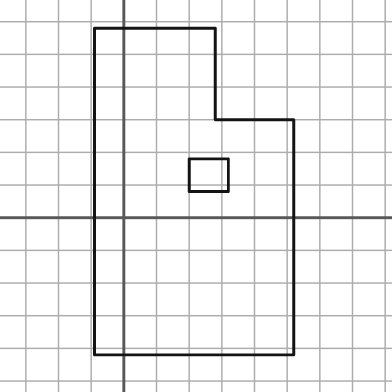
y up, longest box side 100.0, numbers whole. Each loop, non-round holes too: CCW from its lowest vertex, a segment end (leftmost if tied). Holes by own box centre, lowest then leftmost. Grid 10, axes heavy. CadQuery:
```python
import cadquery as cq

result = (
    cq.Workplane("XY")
    .moveTo(-9.0, -42.0)
    .lineTo(52.0, -42.0)
    .lineTo(52.0, 30.0)
    .lineTo(28.0, 30.0)
    .lineTo(28.0, 58.0)
    .lineTo(-9.0, 58.0)
    .close()
    .moveTo(20.0, 8.0)
    .lineTo(32.0, 8.0)
    .lineTo(32.0, 18.0)
    .lineTo(20.0, 18.0)
    .close()
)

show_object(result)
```